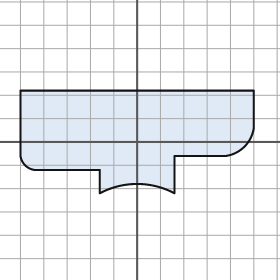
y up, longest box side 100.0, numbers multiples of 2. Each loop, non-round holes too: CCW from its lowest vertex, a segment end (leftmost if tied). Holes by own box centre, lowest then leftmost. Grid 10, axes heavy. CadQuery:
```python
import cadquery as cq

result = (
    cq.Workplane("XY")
    .moveTo(-16.0, -22.0)
    .threePointArc((0.0, -18.0), (16.0, -22.0))
    .lineTo(16.0, -6.0)
    .lineTo(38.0, -6.0)
    .threePointArc((46.0, -2.0), (50.0, 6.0))
    .lineTo(50.0, 22.0)
    .lineTo(-50.0, 22.0)
    .lineTo(-50.0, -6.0)
    .threePointArc((-48.0, -10.0), (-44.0, -12.0))
    .lineTo(-16.0, -12.0)
    .close()
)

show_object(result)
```